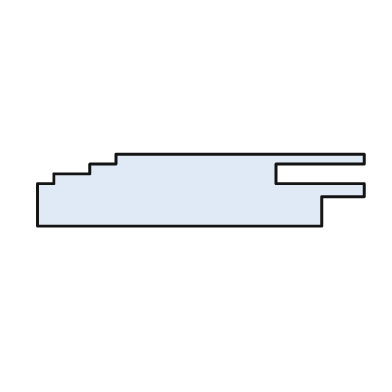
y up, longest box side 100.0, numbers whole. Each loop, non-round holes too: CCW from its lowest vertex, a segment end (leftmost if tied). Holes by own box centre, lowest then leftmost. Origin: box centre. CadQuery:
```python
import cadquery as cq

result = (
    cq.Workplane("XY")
    .moveTo(-50.0, -11.0)
    .lineTo(37.0, -11.0)
    .lineTo(37.0, -2.0)
    .lineTo(50.0, -2.0)
    .lineTo(50.0, 2.0)
    .lineTo(23.0, 2.0)
    .lineTo(23.0, 8.0)
    .lineTo(50.0, 8.0)
    .lineTo(50.0, 11.0)
    .lineTo(-26.0, 11.0)
    .lineTo(-26.0, 8.0)
    .lineTo(-34.0, 8.0)
    .lineTo(-34.0, 5.0)
    .lineTo(-45.0, 5.0)
    .lineTo(-45.0, 2.0)
    .lineTo(-50.0, 2.0)
    .close()
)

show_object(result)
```